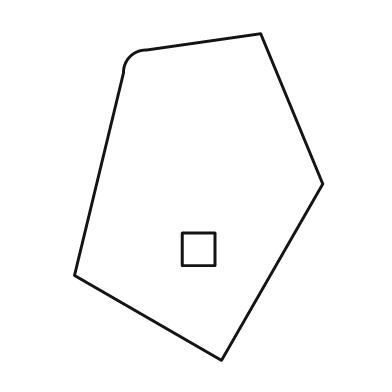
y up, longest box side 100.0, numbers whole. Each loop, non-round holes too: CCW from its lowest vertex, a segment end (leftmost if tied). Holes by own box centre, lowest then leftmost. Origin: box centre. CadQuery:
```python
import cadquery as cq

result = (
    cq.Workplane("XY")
    .moveTo(7.0, -50.0)
    .lineTo(38.0, 4.0)
    .lineTo(19.0, 50.0)
    .lineTo(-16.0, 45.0)
    .threePointArc((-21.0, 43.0), (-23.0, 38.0))
    .lineTo(-38.0, -24.0)
    .close()
    .moveTo(-5.0, -21.0)
    .lineTo(5.0, -21.0)
    .lineTo(5.0, -11.0)
    .lineTo(-5.0, -11.0)
    .close()
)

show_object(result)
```